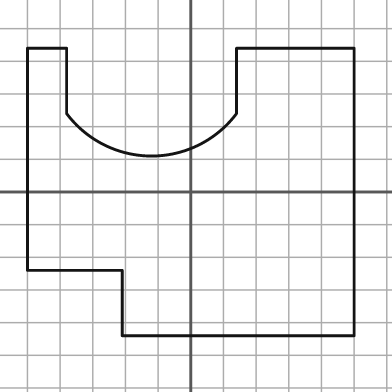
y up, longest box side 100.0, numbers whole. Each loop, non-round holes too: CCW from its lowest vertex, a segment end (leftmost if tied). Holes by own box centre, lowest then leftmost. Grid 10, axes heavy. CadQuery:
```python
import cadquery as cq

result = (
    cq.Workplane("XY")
    .moveTo(-21.0, -44.0)
    .lineTo(50.0, -44.0)
    .lineTo(50.0, 44.0)
    .lineTo(14.0, 44.0)
    .lineTo(14.0, 24.0)
    .threePointArc((-12.0, 11.0), (-38.0, 24.0))
    .lineTo(-38.0, 44.0)
    .lineTo(-50.0, 44.0)
    .lineTo(-50.0, -24.0)
    .lineTo(-21.0, -24.0)
    .close()
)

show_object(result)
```